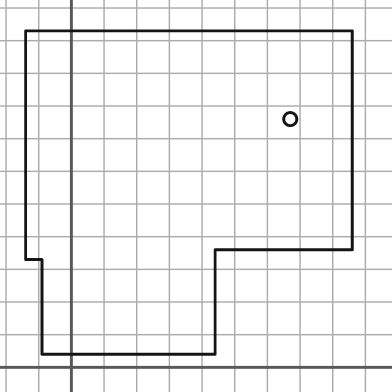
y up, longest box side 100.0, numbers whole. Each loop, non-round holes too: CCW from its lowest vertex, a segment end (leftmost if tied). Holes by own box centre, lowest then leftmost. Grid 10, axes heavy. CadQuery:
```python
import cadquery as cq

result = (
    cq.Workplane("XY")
    .moveTo(-9.0, 4.0)
    .lineTo(44.0, 4.0)
    .lineTo(44.0, 36.0)
    .lineTo(86.0, 36.0)
    .lineTo(86.0, 103.0)
    .lineTo(-14.0, 103.0)
    .lineTo(-14.0, 33.0)
    .lineTo(-9.0, 33.0)
    .close()
    .moveTo(67.0, 76.0)
    .circle(2.0)
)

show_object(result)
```